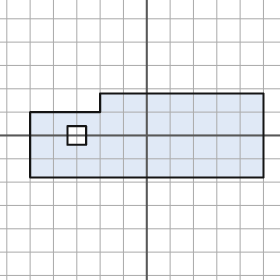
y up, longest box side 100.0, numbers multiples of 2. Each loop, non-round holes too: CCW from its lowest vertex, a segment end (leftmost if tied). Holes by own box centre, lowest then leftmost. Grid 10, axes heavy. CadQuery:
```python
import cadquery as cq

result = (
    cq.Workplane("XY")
    .moveTo(-50.0, -18.0)
    .lineTo(50.0, -18.0)
    .lineTo(50.0, 18.0)
    .lineTo(-20.0, 18.0)
    .lineTo(-20.0, 10.0)
    .lineTo(-50.0, 10.0)
    .close()
    .moveTo(-34.0, -4.0)
    .lineTo(-26.0, -4.0)
    .lineTo(-26.0, 4.0)
    .lineTo(-34.0, 4.0)
    .close()
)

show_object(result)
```